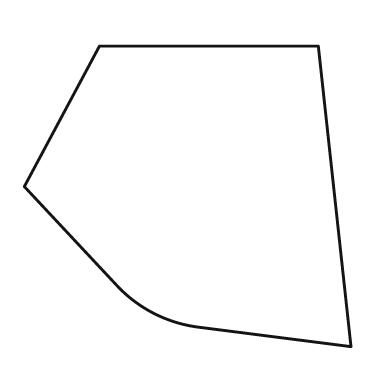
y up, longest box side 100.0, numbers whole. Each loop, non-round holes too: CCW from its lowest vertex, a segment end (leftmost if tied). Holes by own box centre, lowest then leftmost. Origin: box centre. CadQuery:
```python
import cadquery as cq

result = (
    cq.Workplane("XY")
    .moveTo(50.0, -46.0)
    .lineTo(40.0, 46.0)
    .lineTo(-27.0, 46.0)
    .lineTo(-50.0, 3.0)
    .lineTo(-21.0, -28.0)
    .threePointArc((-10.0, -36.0), (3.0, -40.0))
    .close()
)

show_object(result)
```